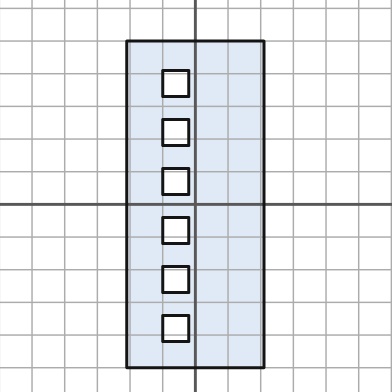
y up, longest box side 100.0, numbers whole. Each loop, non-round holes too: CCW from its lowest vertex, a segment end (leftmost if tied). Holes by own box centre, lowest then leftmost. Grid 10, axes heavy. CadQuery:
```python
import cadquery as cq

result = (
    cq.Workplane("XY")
    .moveTo(-21.0, -50.0)
    .lineTo(21.0, -50.0)
    .lineTo(21.0, 50.0)
    .lineTo(-21.0, 50.0)
    .close()
    .moveTo(-10.0, -42.0)
    .lineTo(-2.0, -42.0)
    .lineTo(-2.0, -34.0)
    .lineTo(-10.0, -34.0)
    .close()
    .moveTo(-10.0, -27.0)
    .lineTo(-2.0, -27.0)
    .lineTo(-2.0, -19.0)
    .lineTo(-10.0, -19.0)
    .close()
    .moveTo(-10.0, -12.0)
    .lineTo(-2.0, -12.0)
    .lineTo(-2.0, -4.0)
    .lineTo(-10.0, -4.0)
    .close()
    .moveTo(-10.0, 3.0)
    .lineTo(-2.0, 3.0)
    .lineTo(-2.0, 11.0)
    .lineTo(-10.0, 11.0)
    .close()
    .moveTo(-10.0, 18.0)
    .lineTo(-2.0, 18.0)
    .lineTo(-2.0, 26.0)
    .lineTo(-10.0, 26.0)
    .close()
    .moveTo(-10.0, 33.0)
    .lineTo(-2.0, 33.0)
    .lineTo(-2.0, 41.0)
    .lineTo(-10.0, 41.0)
    .close()
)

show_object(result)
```